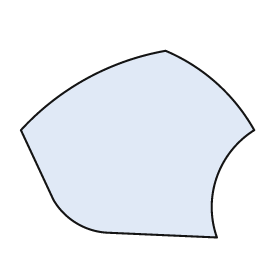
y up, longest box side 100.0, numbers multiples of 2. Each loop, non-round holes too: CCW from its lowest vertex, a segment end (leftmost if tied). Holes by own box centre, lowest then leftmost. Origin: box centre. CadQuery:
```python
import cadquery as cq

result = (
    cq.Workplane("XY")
    .moveTo(34.0, -40.0)
    .threePointArc((34.0, -14.0), (50.0, 6.0))
    .threePointArc((34.0, 26.0), (12.0, 40.0))
    .threePointArc((-22.0, 28.0), (-50.0, 6.0))
    .lineTo(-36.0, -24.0)
    .threePointArc((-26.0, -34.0), (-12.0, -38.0))
    .close()
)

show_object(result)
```